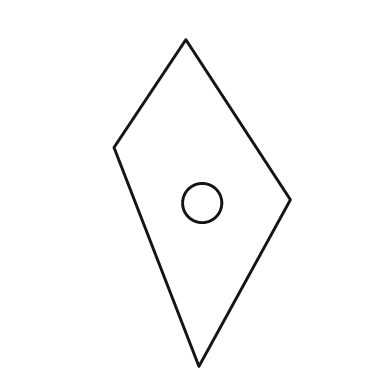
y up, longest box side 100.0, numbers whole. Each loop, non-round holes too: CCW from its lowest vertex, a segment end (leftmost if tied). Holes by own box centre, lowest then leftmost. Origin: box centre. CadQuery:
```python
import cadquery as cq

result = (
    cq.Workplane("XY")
    .moveTo(-1.0, -50.0)
    .lineTo(27.0, 1.0)
    .lineTo(-5.0, 50.0)
    .lineTo(-27.0, 17.0)
    .close()
    .moveTo(0.0, 0.0)
    .circle(6.0)
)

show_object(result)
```